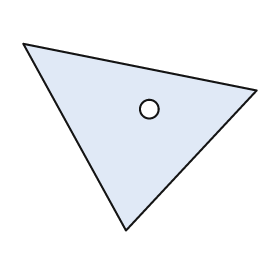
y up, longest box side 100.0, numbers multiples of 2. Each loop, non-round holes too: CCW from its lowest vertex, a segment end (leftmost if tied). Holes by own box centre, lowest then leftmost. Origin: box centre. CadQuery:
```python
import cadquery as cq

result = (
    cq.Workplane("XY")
    .moveTo(-6.0, -40.0)
    .lineTo(50.0, 20.0)
    .lineTo(-50.0, 40.0)
    .close()
    .moveTo(4.0, 12.0)
    .circle(4.0)
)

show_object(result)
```